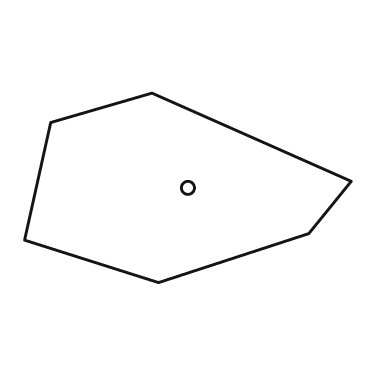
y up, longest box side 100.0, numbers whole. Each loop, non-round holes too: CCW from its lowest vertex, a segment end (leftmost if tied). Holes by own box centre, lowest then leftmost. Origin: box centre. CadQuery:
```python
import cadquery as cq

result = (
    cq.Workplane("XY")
    .moveTo(-9.0, -29.0)
    .lineTo(37.0, -14.0)
    .lineTo(50.0, 2.0)
    .lineTo(-11.0, 29.0)
    .lineTo(-42.0, 20.0)
    .lineTo(-50.0, -16.0)
    .close()
    .moveTo(0.0, 0.0)
    .circle(2.0)
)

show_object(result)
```